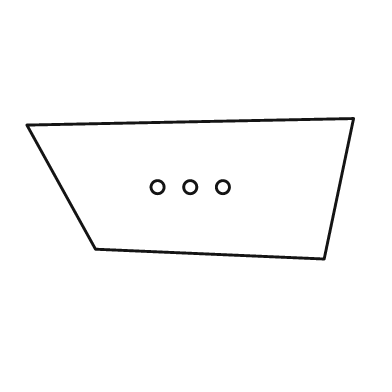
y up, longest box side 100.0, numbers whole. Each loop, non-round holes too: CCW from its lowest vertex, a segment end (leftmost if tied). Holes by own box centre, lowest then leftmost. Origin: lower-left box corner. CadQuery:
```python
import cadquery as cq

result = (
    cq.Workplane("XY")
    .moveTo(91.0, 0.0)
    .lineTo(100.0, 43.0)
    .lineTo(0.0, 41.0)
    .lineTo(21.0, 3.0)
    .close()
    .moveTo(40.0, 22.0)
    .circle(2.0)
    .moveTo(50.0, 22.0)
    .circle(2.0)
    .moveTo(60.0, 22.0)
    .circle(2.0)
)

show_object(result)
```